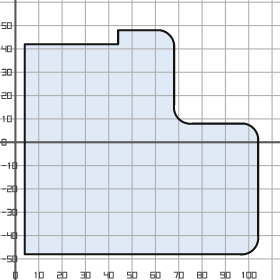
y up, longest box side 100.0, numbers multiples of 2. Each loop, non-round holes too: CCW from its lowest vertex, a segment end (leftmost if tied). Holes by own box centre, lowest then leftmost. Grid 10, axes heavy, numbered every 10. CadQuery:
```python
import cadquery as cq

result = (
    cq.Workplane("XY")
    .moveTo(4.0, -48.0)
    .lineTo(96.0, -48.0)
    .threePointArc((102.0, -46.0), (104.0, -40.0))
    .lineTo(104.0, 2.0)
    .threePointArc((102.0, 6.0), (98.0, 8.0))
    .lineTo(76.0, 8.0)
    .threePointArc((70.0, 10.0), (68.0, 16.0))
    .lineTo(68.0, 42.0)
    .threePointArc((66.0, 46.0), (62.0, 48.0))
    .lineTo(44.0, 48.0)
    .lineTo(44.0, 42.0)
    .lineTo(4.0, 42.0)
    .close()
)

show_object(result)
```